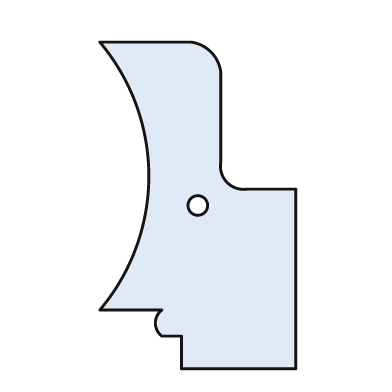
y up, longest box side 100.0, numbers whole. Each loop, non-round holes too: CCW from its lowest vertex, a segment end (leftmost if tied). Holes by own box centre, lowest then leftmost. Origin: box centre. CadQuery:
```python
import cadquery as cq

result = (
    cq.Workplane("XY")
    .moveTo(-5.0, -50.0)
    .lineTo(30.0, -50.0)
    .lineTo(30.0, 5.0)
    .lineTo(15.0, 5.0)
    .threePointArc((9.0, 7.0), (7.0, 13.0))
    .lineTo(7.0, 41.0)
    .threePointArc((4.0, 47.0), (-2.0, 50.0))
    .lineTo(-30.0, 50.0)
    .threePointArc((-15.0, 9.0), (-30.0, -32.0))
    .lineTo(-11.0, -32.0)
    .threePointArc((-13.0, -36.0), (-11.0, -40.0))
    .lineTo(-5.0, -40.0)
    .close()
    .moveTo(0.0, 0.0)
    .circle(3.0)
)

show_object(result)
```